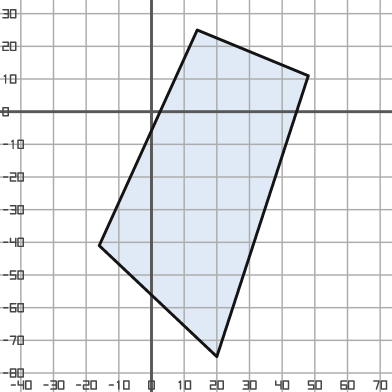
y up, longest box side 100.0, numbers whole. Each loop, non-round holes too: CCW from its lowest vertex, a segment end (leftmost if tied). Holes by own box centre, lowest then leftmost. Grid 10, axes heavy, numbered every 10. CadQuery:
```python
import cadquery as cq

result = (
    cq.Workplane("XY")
    .moveTo(20.0, -75.0)
    .lineTo(48.0, 11.0)
    .lineTo(14.0, 25.0)
    .lineTo(-16.0, -41.0)
    .close()
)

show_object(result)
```